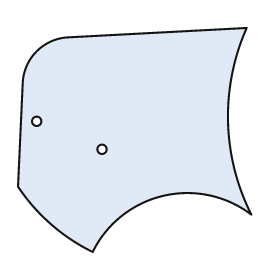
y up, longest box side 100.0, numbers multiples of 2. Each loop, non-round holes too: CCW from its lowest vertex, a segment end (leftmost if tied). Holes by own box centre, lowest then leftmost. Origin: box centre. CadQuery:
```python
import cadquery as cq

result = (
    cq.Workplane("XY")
    .moveTo(-18.0, -48.0)
    .threePointArc((12.0, -24.0), (50.0, -32.0))
    .threePointArc((40.0, 8.0), (48.0, 48.0))
    .lineTo(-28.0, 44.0)
    .threePointArc((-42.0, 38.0), (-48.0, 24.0))
    .lineTo(-50.0, -20.0)
    .threePointArc((-36.0, -36.0), (-18.0, -48.0))
    .close()
    .moveTo(-14.0, -4.0)
    .circle(2.0)
    .moveTo(-42.0, 8.0)
    .circle(2.0)
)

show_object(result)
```